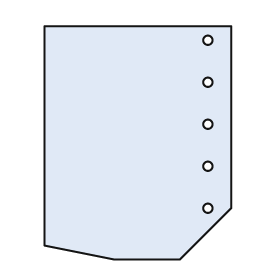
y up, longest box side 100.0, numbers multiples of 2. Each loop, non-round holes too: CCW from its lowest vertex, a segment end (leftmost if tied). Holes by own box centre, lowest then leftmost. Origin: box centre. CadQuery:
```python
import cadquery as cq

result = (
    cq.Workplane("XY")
    .moveTo(-10.0, -50.0)
    .lineTo(18.0, -50.0)
    .lineTo(40.0, -28.0)
    .lineTo(40.0, 50.0)
    .lineTo(-40.0, 50.0)
    .lineTo(-40.0, -44.0)
    .close()
    .moveTo(30.0, -28.0)
    .circle(2.0)
    .moveTo(30.0, -10.0)
    .circle(2.0)
    .moveTo(30.0, 8.0)
    .circle(2.0)
    .moveTo(30.0, 26.0)
    .circle(2.0)
    .moveTo(30.0, 44.0)
    .circle(2.0)
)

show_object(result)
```